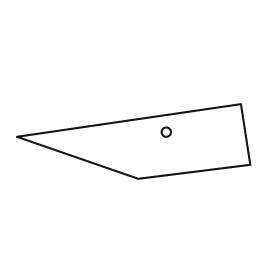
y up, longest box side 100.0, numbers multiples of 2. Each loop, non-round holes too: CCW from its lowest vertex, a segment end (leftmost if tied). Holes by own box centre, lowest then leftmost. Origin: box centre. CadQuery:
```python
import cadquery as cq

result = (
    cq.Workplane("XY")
    .moveTo(2.0, -16.0)
    .lineTo(50.0, -10.0)
    .lineTo(46.0, 16.0)
    .lineTo(-50.0, 2.0)
    .close()
    .moveTo(14.0, 4.0)
    .circle(2.0)
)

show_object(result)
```